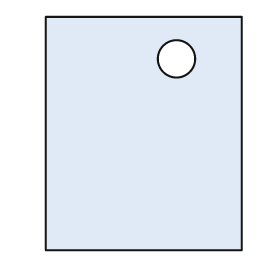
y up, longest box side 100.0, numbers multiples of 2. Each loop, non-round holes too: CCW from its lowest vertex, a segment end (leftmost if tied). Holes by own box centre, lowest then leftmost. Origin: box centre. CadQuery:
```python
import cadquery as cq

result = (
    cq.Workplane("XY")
    .moveTo(-42.0, -50.0)
    .lineTo(42.0, -50.0)
    .lineTo(42.0, 50.0)
    .lineTo(-42.0, 50.0)
    .close()
    .moveTo(14.0, 32.0)
    .circle(8.0)
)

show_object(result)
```